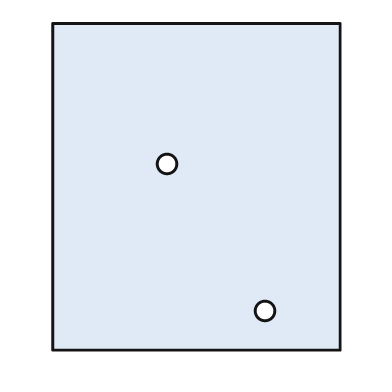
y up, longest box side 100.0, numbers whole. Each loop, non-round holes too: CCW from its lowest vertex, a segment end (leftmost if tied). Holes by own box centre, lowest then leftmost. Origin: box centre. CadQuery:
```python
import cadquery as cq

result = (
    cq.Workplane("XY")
    .moveTo(-44.0, -50.0)
    .lineTo(44.0, -50.0)
    .lineTo(44.0, 50.0)
    .lineTo(-44.0, 50.0)
    .close()
    .moveTo(21.0, -38.0)
    .circle(3.0)
    .moveTo(-9.0, 7.0)
    .circle(3.0)
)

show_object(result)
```